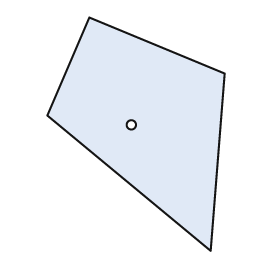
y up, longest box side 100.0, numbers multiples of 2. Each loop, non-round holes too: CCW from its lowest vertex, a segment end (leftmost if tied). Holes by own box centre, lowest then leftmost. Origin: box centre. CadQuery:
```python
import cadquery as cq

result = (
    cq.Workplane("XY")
    .moveTo(32.0, -50.0)
    .lineTo(38.0, 26.0)
    .lineTo(-20.0, 50.0)
    .lineTo(-38.0, 8.0)
    .close()
    .moveTo(-2.0, 4.0)
    .circle(2.0)
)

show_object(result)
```